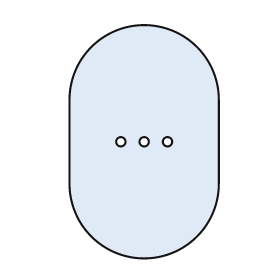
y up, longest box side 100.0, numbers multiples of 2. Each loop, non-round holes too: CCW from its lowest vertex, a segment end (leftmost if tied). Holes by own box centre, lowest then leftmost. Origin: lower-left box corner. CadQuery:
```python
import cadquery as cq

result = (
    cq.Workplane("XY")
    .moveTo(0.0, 32.0)
    .threePointArc((32.0, 0.0), (64.0, 32.0))
    .lineTo(64.0, 68.0)
    .threePointArc((32.0, 100.0), (0.0, 68.0))
    .close()
    .moveTo(22.0, 50.0)
    .circle(2.0)
    .moveTo(32.0, 50.0)
    .circle(2.0)
    .moveTo(42.0, 50.0)
    .circle(2.0)
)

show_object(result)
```